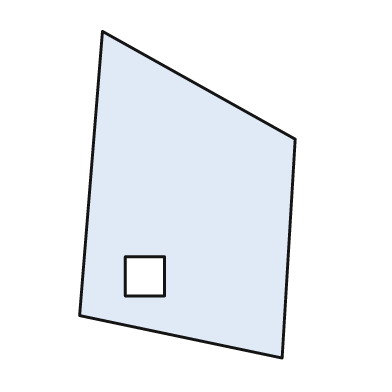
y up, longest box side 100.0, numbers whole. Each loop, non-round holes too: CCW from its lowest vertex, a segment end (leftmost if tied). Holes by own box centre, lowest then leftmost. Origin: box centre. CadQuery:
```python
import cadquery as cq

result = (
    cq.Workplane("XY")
    .moveTo(29.0, -50.0)
    .lineTo(33.0, 17.0)
    .lineTo(-26.0, 50.0)
    .lineTo(-33.0, -37.0)
    .close()
    .moveTo(-19.0, -31.0)
    .lineTo(-7.0, -31.0)
    .lineTo(-7.0, -19.0)
    .lineTo(-19.0, -19.0)
    .close()
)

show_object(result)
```